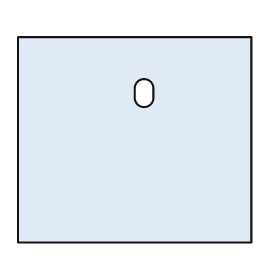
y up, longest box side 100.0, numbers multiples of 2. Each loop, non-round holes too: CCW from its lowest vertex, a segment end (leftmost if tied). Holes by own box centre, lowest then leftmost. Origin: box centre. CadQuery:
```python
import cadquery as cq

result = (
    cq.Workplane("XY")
    .moveTo(-50.0, -44.0)
    .lineTo(50.0, -44.0)
    .lineTo(50.0, 44.0)
    .lineTo(-50.0, 44.0)
    .close()
    .moveTo(0.0, 18.0)
    .threePointArc((4.0, 14.0), (8.0, 18.0))
    .lineTo(8.0, 22.0)
    .threePointArc((4.0, 26.0), (0.0, 22.0))
    .close()
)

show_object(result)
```